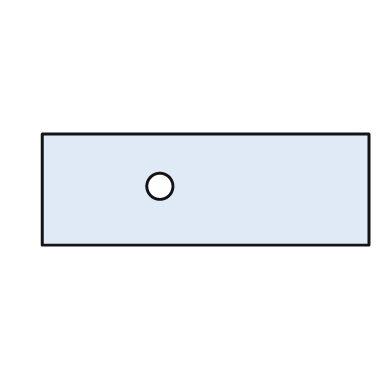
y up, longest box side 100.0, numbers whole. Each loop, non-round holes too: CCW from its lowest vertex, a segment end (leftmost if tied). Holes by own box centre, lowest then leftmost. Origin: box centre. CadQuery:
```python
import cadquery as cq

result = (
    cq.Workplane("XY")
    .moveTo(-50.0, -17.0)
    .lineTo(50.0, -17.0)
    .lineTo(50.0, 17.0)
    .lineTo(-50.0, 17.0)
    .close()
    .moveTo(-14.0, 1.0)
    .circle(4.0)
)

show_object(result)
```